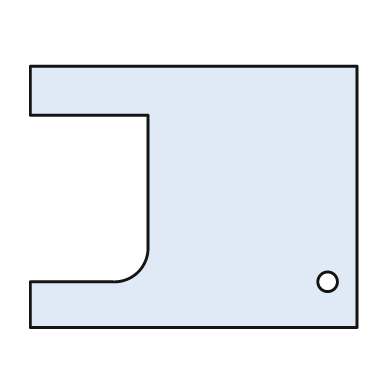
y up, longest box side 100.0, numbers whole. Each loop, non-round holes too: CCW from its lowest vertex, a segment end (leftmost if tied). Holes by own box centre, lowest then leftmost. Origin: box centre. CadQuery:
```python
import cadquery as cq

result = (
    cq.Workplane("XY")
    .moveTo(-50.0, -40.0)
    .lineTo(50.0, -40.0)
    .lineTo(50.0, 40.0)
    .lineTo(-50.0, 40.0)
    .lineTo(-50.0, 25.0)
    .lineTo(-14.0, 25.0)
    .lineTo(-14.0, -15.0)
    .threePointArc((-17.0, -23.0), (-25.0, -26.0))
    .lineTo(-50.0, -26.0)
    .close()
    .moveTo(41.0, -26.0)
    .circle(3.0)
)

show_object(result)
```